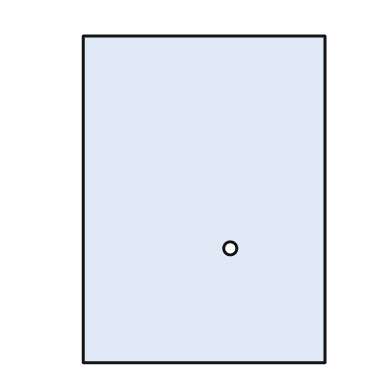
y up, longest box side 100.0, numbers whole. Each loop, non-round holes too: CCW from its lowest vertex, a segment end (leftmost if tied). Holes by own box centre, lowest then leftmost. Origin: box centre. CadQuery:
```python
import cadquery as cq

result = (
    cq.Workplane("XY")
    .moveTo(-37.0, -50.0)
    .lineTo(37.0, -50.0)
    .lineTo(37.0, 50.0)
    .lineTo(-37.0, 50.0)
    .close()
    .moveTo(8.0, -15.0)
    .circle(2.0)
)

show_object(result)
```